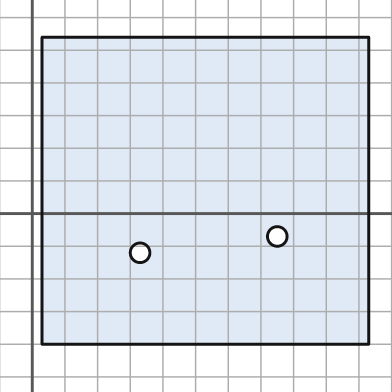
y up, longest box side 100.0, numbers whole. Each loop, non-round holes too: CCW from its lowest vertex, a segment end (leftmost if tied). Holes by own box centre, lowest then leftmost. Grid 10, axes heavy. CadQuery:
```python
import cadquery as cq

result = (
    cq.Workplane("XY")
    .moveTo(3.0, -40.0)
    .lineTo(103.0, -40.0)
    .lineTo(103.0, 54.0)
    .lineTo(3.0, 54.0)
    .close()
    .moveTo(33.0, -12.0)
    .circle(3.0)
    .moveTo(75.0, -7.0)
    .circle(3.0)
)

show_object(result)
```